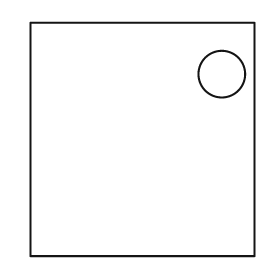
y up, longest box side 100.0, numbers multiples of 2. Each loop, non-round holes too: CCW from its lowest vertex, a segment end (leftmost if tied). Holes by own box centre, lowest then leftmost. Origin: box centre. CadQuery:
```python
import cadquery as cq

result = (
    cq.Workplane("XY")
    .moveTo(-48.0, -50.0)
    .lineTo(48.0, -50.0)
    .lineTo(48.0, 50.0)
    .lineTo(-48.0, 50.0)
    .close()
    .moveTo(34.0, 28.0)
    .circle(10.0)
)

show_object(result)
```